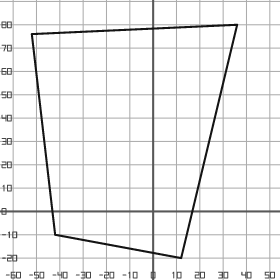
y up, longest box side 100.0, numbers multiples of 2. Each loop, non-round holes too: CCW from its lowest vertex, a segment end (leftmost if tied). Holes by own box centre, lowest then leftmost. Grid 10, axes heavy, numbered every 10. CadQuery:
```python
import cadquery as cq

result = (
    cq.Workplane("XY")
    .moveTo(12.0, -20.0)
    .lineTo(36.0, 80.0)
    .lineTo(-52.0, 76.0)
    .lineTo(-42.0, -10.0)
    .close()
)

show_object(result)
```